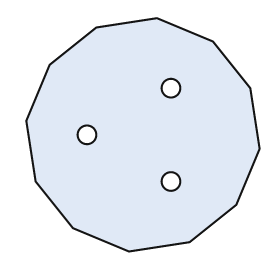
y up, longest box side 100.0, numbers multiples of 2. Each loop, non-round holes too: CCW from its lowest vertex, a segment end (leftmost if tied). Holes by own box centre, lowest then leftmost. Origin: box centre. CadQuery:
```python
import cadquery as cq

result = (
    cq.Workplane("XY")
    .moveTo(-6.0, -50.0)
    .lineTo(20.0, -46.0)
    .lineTo(40.0, -30.0)
    .lineTo(50.0, -6.0)
    .lineTo(46.0, 20.0)
    .lineTo(30.0, 40.0)
    .lineTo(6.0, 50.0)
    .lineTo(-20.0, 46.0)
    .lineTo(-40.0, 30.0)
    .lineTo(-50.0, 6.0)
    .lineTo(-46.0, -20.0)
    .lineTo(-30.0, -40.0)
    .close()
    .moveTo(12.0, -20.0)
    .circle(4.0)
    .moveTo(-24.0, 0.0)
    .circle(4.0)
    .moveTo(12.0, 20.0)
    .circle(4.0)
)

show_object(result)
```